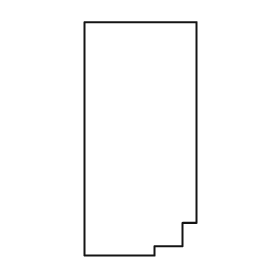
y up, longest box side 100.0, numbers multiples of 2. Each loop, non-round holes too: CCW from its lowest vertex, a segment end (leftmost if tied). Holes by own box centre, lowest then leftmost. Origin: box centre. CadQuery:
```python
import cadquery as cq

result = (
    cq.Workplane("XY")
    .moveTo(-24.0, -50.0)
    .lineTo(6.0, -50.0)
    .lineTo(6.0, -46.0)
    .lineTo(18.0, -46.0)
    .lineTo(18.0, -36.0)
    .lineTo(24.0, -36.0)
    .lineTo(24.0, 50.0)
    .lineTo(-24.0, 50.0)
    .close()
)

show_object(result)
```